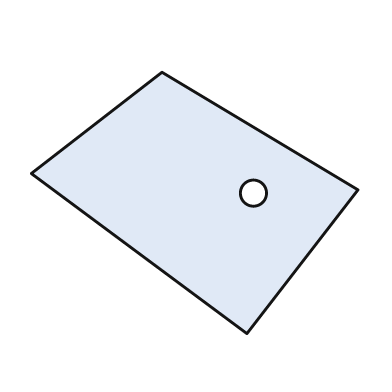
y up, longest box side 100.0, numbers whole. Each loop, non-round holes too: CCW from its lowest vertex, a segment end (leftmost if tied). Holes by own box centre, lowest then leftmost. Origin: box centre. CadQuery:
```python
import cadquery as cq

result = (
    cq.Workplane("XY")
    .moveTo(16.0, -40.0)
    .lineTo(50.0, 4.0)
    .lineTo(-10.0, 40.0)
    .lineTo(-50.0, 9.0)
    .close()
    .moveTo(18.0, 3.0)
    .circle(4.0)
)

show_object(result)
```